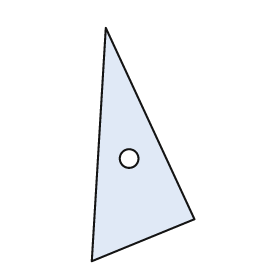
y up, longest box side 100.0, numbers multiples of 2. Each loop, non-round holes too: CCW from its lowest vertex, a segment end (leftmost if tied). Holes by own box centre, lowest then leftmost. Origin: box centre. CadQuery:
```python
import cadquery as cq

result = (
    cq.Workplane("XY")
    .moveTo(-22.0, -50.0)
    .lineTo(22.0, -32.0)
    .lineTo(-16.0, 50.0)
    .close()
    .moveTo(-6.0, -6.0)
    .circle(4.0)
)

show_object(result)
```